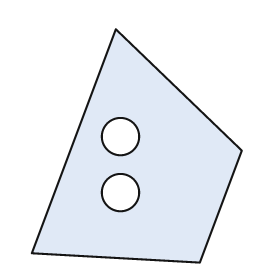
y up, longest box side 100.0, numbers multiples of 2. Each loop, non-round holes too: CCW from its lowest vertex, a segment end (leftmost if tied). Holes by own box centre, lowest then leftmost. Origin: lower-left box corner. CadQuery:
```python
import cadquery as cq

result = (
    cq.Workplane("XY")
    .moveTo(72.0, 0.0)
    .lineTo(90.0, 48.0)
    .lineTo(36.0, 100.0)
    .lineTo(0.0, 4.0)
    .close()
    .moveTo(38.0, 30.0)
    .circle(8.0)
    .moveTo(38.0, 54.0)
    .circle(8.0)
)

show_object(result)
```